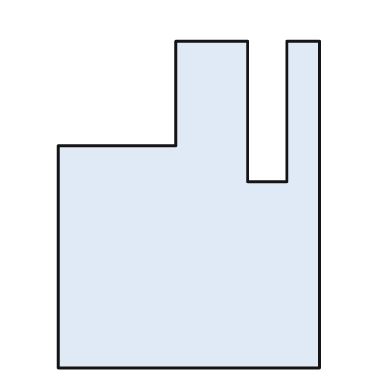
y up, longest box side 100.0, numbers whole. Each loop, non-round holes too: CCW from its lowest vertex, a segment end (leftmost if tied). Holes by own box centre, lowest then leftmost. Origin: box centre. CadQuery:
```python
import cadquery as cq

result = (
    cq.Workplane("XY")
    .moveTo(-40.0, -50.0)
    .lineTo(40.0, -50.0)
    .lineTo(40.0, 50.0)
    .lineTo(30.0, 50.0)
    .lineTo(30.0, 7.0)
    .lineTo(18.0, 7.0)
    .lineTo(18.0, 50.0)
    .lineTo(-4.0, 50.0)
    .lineTo(-4.0, 18.0)
    .lineTo(-40.0, 18.0)
    .close()
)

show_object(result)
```